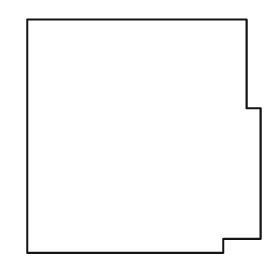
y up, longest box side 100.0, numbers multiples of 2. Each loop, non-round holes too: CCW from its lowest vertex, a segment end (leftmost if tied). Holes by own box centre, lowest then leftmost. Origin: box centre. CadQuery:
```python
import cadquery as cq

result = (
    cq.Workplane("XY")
    .moveTo(-50.0, -50.0)
    .lineTo(34.0, -50.0)
    .lineTo(34.0, -44.0)
    .lineTo(50.0, -44.0)
    .lineTo(50.0, 12.0)
    .lineTo(44.0, 12.0)
    .lineTo(44.0, 50.0)
    .lineTo(-50.0, 50.0)
    .close()
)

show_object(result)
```